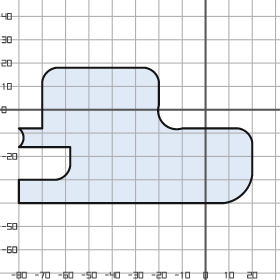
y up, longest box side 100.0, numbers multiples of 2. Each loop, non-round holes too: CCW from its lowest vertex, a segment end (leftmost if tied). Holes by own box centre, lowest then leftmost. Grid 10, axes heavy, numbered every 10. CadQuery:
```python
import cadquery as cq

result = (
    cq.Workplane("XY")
    .moveTo(-80.0, -40.0)
    .lineTo(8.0, -40.0)
    .threePointArc((16.0, -36.0), (20.0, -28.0))
    .lineTo(20.0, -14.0)
    .threePointArc((18.0, -10.0), (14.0, -8.0))
    .lineTo(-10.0, -8.0)
    .threePointArc((-18.0, -6.0), (-20.0, 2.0))
    .lineTo(-20.0, 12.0)
    .threePointArc((-22.0, 16.0), (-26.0, 18.0))
    .lineTo(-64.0, 18.0)
    .threePointArc((-68.0, 16.0), (-70.0, 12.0))
    .lineTo(-70.0, -8.0)
    .lineTo(-80.0, -8.0)
    .threePointArc((-78.0, -12.0), (-80.0, -16.0))
    .lineTo(-58.0, -16.0)
    .lineTo(-58.0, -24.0)
    .threePointArc((-60.0, -28.0), (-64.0, -30.0))
    .lineTo(-80.0, -30.0)
    .close()
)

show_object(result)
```